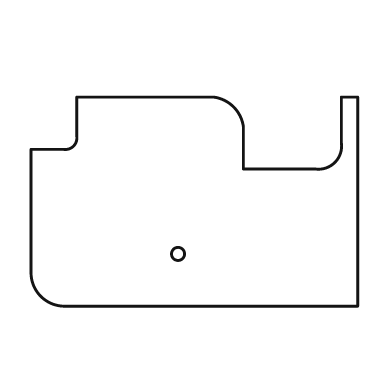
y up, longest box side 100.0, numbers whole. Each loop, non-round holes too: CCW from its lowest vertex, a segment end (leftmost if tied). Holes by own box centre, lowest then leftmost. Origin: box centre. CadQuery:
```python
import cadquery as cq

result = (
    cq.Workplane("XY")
    .moveTo(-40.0, -32.0)
    .lineTo(50.0, -32.0)
    .lineTo(50.0, 32.0)
    .lineTo(45.0, 32.0)
    .lineTo(45.0, 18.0)
    .threePointArc((43.0, 12.0), (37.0, 10.0))
    .lineTo(15.0, 10.0)
    .lineTo(15.0, 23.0)
    .threePointArc((12.0, 29.0), (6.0, 32.0))
    .lineTo(-36.0, 32.0)
    .lineTo(-36.0, 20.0)
    .threePointArc((-37.0, 17.0), (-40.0, 16.0))
    .lineTo(-50.0, 16.0)
    .lineTo(-50.0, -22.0)
    .threePointArc((-47.0, -29.0), (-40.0, -32.0))
    .close()
    .moveTo(-5.0, -16.0)
    .circle(2.0)
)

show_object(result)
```